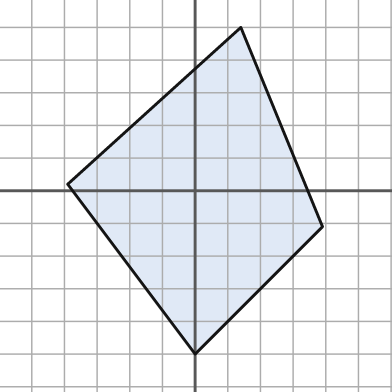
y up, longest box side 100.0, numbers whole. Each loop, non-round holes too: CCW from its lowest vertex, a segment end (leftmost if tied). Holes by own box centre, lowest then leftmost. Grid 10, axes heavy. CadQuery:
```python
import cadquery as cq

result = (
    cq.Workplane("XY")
    .moveTo(0.0, -50.0)
    .lineTo(39.0, -11.0)
    .lineTo(14.0, 50.0)
    .lineTo(-39.0, 2.0)
    .close()
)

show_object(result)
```